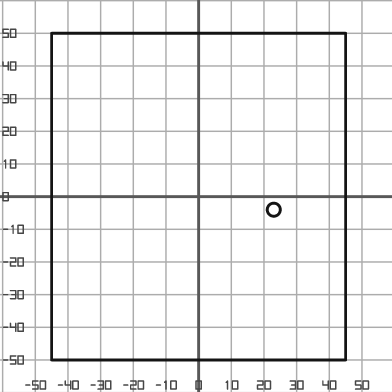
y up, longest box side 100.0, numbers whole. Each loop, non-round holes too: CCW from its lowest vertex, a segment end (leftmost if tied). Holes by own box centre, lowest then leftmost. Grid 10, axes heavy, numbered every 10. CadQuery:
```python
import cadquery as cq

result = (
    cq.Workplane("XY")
    .moveTo(-45.0, -50.0)
    .lineTo(45.0, -50.0)
    .lineTo(45.0, 50.0)
    .lineTo(-45.0, 50.0)
    .close()
    .moveTo(23.0, -4.0)
    .circle(2.0)
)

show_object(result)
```